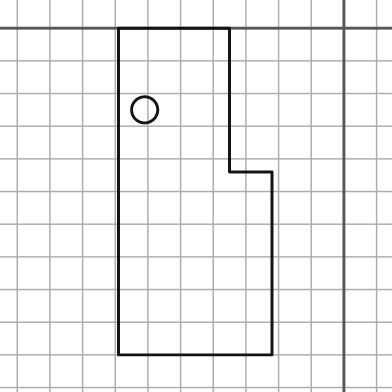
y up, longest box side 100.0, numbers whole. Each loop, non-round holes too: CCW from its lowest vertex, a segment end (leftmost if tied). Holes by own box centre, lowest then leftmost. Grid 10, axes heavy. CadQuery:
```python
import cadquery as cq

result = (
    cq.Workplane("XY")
    .moveTo(-69.0, -100.0)
    .lineTo(-22.0, -100.0)
    .lineTo(-22.0, -44.0)
    .lineTo(-35.0, -44.0)
    .lineTo(-35.0, 0.0)
    .lineTo(-69.0, 0.0)
    .close()
    .moveTo(-61.0, -25.0)
    .circle(4.0)
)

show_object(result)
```